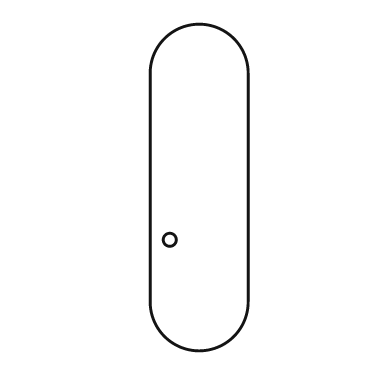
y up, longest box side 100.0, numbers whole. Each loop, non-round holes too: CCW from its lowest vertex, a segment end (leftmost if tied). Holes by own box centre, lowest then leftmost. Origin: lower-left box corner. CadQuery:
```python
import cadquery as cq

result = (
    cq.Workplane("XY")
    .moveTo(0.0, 15.0)
    .threePointArc((15.0, 0.0), (30.0, 15.0))
    .lineTo(30.0, 85.0)
    .threePointArc((15.0, 100.0), (0.0, 85.0))
    .close()
    .moveTo(6.0, 34.0)
    .circle(2.0)
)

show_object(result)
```